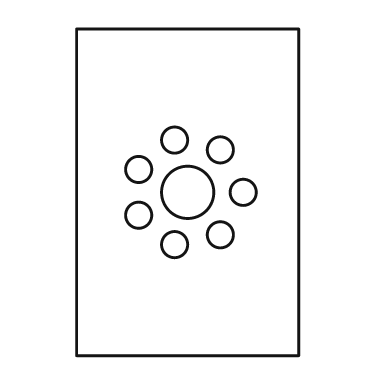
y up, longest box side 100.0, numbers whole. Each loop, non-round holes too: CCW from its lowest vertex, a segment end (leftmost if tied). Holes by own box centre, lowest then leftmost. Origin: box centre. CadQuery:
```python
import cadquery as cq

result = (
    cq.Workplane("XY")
    .moveTo(-34.0, -50.0)
    .lineTo(34.0, -50.0)
    .lineTo(34.0, 50.0)
    .lineTo(-34.0, 50.0)
    .close()
    .moveTo(-4.0, -16.0)
    .circle(4.0)
    .moveTo(10.0, -13.0)
    .circle(4.0)
    .moveTo(-15.0, -7.0)
    .circle(4.0)
    .moveTo(0.0, 0.0)
    .circle(8.0)
    .moveTo(17.0, 0.0)
    .circle(4.0)
    .moveTo(-15.0, 7.0)
    .circle(4.0)
    .moveTo(10.0, 13.0)
    .circle(4.0)
    .moveTo(-4.0, 16.0)
    .circle(4.0)
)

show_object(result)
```